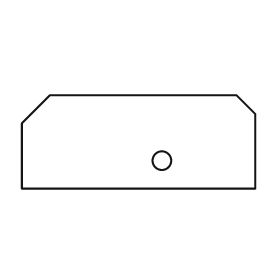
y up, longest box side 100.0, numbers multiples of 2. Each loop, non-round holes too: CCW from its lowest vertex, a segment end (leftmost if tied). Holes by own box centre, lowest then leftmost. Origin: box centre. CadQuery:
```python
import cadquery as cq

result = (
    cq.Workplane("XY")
    .moveTo(-50.0, -20.0)
    .lineTo(50.0, -20.0)
    .lineTo(50.0, 12.0)
    .lineTo(42.0, 20.0)
    .lineTo(-38.0, 20.0)
    .lineTo(-50.0, 8.0)
    .close()
    .moveTo(10.0, -8.0)
    .circle(4.0)
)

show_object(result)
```